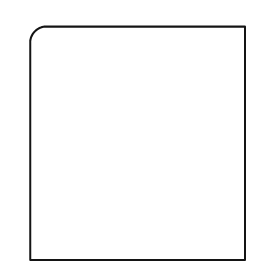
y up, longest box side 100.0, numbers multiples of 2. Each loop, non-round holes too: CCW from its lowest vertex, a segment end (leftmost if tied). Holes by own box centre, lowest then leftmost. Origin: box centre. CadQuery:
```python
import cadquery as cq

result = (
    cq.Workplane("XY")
    .moveTo(-46.0, -50.0)
    .lineTo(46.0, -50.0)
    .lineTo(46.0, 50.0)
    .lineTo(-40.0, 50.0)
    .threePointArc((-44.0, 48.0), (-46.0, 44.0))
    .close()
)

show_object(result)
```